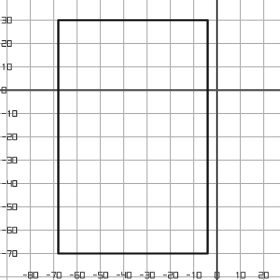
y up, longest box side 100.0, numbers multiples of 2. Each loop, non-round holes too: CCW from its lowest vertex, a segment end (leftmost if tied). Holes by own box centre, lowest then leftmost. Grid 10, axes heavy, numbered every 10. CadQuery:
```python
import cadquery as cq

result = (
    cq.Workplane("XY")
    .moveTo(-68.0, -70.0)
    .lineTo(-4.0, -70.0)
    .lineTo(-4.0, 30.0)
    .lineTo(-68.0, 30.0)
    .close()
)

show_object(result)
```